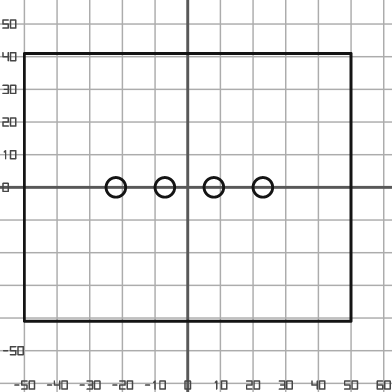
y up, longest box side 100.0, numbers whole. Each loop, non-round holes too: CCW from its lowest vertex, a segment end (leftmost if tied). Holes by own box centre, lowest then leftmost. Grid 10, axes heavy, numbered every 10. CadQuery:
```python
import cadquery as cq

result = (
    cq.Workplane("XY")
    .moveTo(-50.0, -41.0)
    .lineTo(50.0, -41.0)
    .lineTo(50.0, 41.0)
    .lineTo(-50.0, 41.0)
    .close()
    .moveTo(-22.0, 0.0)
    .circle(3.0)
    .moveTo(-7.0, 0.0)
    .circle(3.0)
    .moveTo(8.0, 0.0)
    .circle(3.0)
    .moveTo(23.0, 0.0)
    .circle(3.0)
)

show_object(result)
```